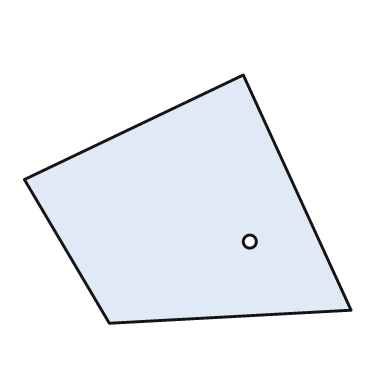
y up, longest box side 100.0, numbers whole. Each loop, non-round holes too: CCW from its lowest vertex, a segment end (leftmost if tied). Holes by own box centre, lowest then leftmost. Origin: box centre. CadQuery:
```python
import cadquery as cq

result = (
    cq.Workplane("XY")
    .moveTo(-24.0, -38.0)
    .lineTo(50.0, -34.0)
    .lineTo(17.0, 38.0)
    .lineTo(-50.0, 6.0)
    .close()
    .moveTo(19.0, -13.0)
    .circle(2.0)
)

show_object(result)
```